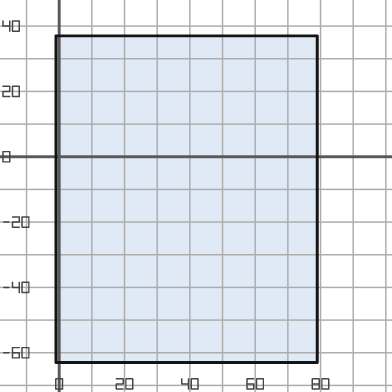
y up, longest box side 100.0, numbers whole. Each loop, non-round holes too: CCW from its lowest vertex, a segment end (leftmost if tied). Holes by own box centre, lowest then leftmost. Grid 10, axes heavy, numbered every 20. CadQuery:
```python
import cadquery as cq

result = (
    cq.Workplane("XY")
    .moveTo(-1.0, -63.0)
    .lineTo(79.0, -63.0)
    .lineTo(79.0, 37.0)
    .lineTo(-1.0, 37.0)
    .close()
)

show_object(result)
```